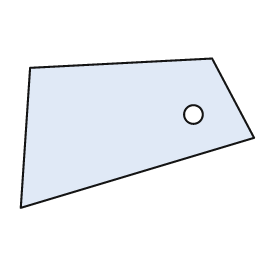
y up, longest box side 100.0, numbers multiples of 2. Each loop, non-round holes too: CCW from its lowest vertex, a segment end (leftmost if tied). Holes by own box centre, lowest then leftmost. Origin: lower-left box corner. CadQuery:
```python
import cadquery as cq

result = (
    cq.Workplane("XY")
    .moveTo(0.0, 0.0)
    .lineTo(100.0, 30.0)
    .lineTo(82.0, 64.0)
    .lineTo(4.0, 60.0)
    .close()
    .moveTo(74.0, 40.0)
    .circle(4.0)
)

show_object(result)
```